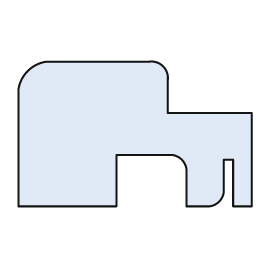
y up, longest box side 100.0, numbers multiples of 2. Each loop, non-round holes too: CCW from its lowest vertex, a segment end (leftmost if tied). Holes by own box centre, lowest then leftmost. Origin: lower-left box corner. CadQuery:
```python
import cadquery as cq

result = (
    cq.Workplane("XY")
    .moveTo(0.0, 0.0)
    .lineTo(42.0, 0.0)
    .lineTo(42.0, 22.0)
    .lineTo(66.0, 22.0)
    .threePointArc((70.0, 20.0), (72.0, 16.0))
    .lineTo(72.0, 0.0)
    .lineTo(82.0, 0.0)
    .threePointArc((86.0, 2.0), (88.0, 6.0))
    .lineTo(88.0, 20.0)
    .lineTo(92.0, 20.0)
    .lineTo(92.0, 0.0)
    .lineTo(100.0, 0.0)
    .lineTo(100.0, 40.0)
    .lineTo(64.0, 40.0)
    .lineTo(64.0, 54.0)
    .threePointArc((62.0, 60.0), (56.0, 62.0))
    .lineTo(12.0, 62.0)
    .threePointArc((4.0, 58.0), (0.0, 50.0))
    .close()
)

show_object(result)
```